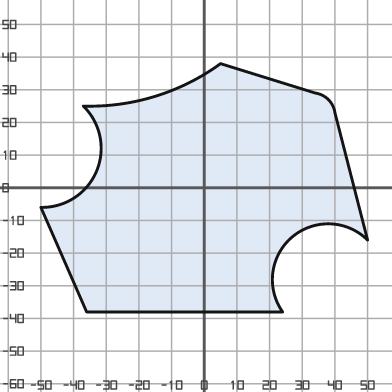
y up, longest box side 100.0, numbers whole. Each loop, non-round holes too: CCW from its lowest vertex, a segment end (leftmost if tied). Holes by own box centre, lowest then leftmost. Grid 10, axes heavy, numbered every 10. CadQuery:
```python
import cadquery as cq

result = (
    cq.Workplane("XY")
    .moveTo(-36.0, -38.0)
    .lineTo(24.0, -38.0)
    .threePointArc((27.0, -15.0), (50.0, -16.0))
    .lineTo(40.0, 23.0)
    .threePointArc((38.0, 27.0), (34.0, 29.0))
    .lineTo(5.0, 38.0)
    .threePointArc((-15.0, 28.0), (-37.0, 25.0))
    .threePointArc((-33.0, 5.0), (-50.0, -6.0))
    .close()
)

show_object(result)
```